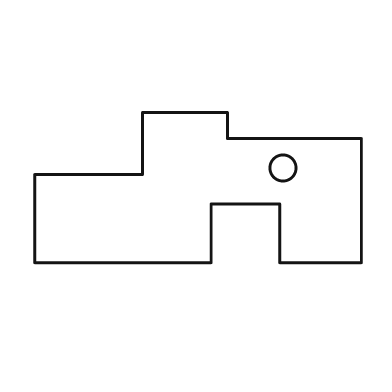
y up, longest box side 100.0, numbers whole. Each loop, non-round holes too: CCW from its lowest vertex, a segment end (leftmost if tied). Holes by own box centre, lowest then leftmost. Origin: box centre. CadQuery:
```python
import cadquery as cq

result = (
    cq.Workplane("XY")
    .moveTo(-50.0, -23.0)
    .lineTo(4.0, -23.0)
    .lineTo(4.0, -5.0)
    .lineTo(25.0, -5.0)
    .lineTo(25.0, -23.0)
    .lineTo(50.0, -23.0)
    .lineTo(50.0, 15.0)
    .lineTo(9.0, 15.0)
    .lineTo(9.0, 23.0)
    .lineTo(-17.0, 23.0)
    .lineTo(-17.0, 4.0)
    .lineTo(-50.0, 4.0)
    .close()
    .moveTo(26.0, 6.0)
    .circle(4.0)
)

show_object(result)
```